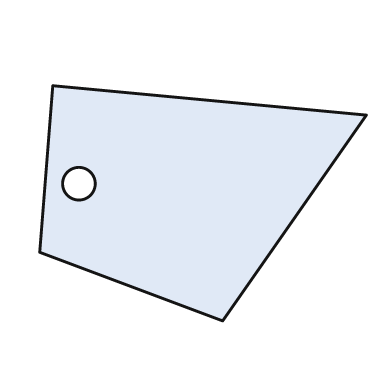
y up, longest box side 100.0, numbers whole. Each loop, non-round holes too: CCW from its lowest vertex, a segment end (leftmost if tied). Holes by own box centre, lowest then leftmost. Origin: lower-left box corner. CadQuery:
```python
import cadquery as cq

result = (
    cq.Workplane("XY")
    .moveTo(56.0, 0.0)
    .lineTo(100.0, 63.0)
    .lineTo(4.0, 72.0)
    .lineTo(0.0, 21.0)
    .close()
    .moveTo(12.0, 42.0)
    .circle(5.0)
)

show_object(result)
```